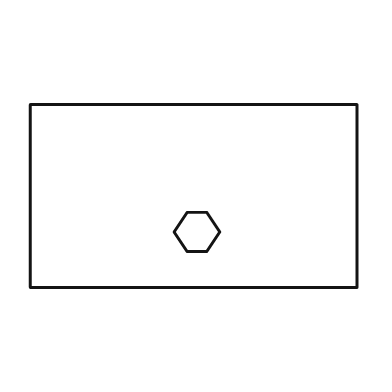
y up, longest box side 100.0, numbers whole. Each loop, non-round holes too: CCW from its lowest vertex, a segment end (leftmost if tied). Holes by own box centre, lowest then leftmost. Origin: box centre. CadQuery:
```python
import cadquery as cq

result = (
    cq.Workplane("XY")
    .moveTo(-50.0, -28.0)
    .lineTo(50.0, -28.0)
    .lineTo(50.0, 28.0)
    .lineTo(-50.0, 28.0)
    .close()
    .moveTo(-2.0, -17.0)
    .lineTo(4.0, -17.0)
    .lineTo(8.0, -11.0)
    .lineTo(4.0, -5.0)
    .lineTo(-2.0, -5.0)
    .lineTo(-6.0, -11.0)
    .close()
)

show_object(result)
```